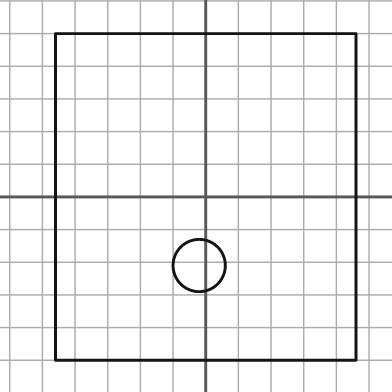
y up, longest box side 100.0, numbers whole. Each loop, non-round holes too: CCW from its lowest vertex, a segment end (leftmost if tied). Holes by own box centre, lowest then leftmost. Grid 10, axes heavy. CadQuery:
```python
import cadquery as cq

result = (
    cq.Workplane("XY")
    .moveTo(-46.0, -50.0)
    .lineTo(46.0, -50.0)
    .lineTo(46.0, 50.0)
    .lineTo(-46.0, 50.0)
    .close()
    .moveTo(-2.0, -21.0)
    .circle(8.0)
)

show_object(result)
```